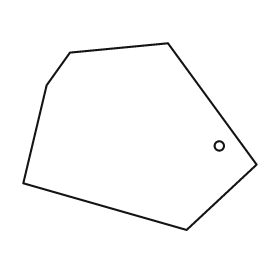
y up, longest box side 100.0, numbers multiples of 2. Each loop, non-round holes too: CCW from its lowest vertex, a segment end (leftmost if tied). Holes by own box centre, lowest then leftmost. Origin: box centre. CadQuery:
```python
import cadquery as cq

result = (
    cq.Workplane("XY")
    .moveTo(20.0, -40.0)
    .lineTo(50.0, -12.0)
    .lineTo(12.0, 40.0)
    .lineTo(-30.0, 36.0)
    .lineTo(-40.0, 22.0)
    .lineTo(-50.0, -20.0)
    .close()
    .moveTo(34.0, -4.0)
    .circle(2.0)
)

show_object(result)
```